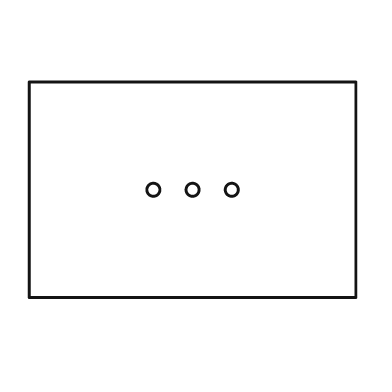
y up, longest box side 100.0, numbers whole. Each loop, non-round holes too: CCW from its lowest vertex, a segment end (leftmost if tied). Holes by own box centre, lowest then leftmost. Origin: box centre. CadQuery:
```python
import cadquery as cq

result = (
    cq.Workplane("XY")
    .moveTo(-50.0, -33.0)
    .lineTo(50.0, -33.0)
    .lineTo(50.0, 33.0)
    .lineTo(-50.0, 33.0)
    .close()
    .moveTo(-12.0, 0.0)
    .circle(2.0)
    .moveTo(0.0, 0.0)
    .circle(2.0)
    .moveTo(12.0, 0.0)
    .circle(2.0)
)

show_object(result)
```